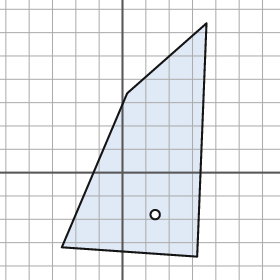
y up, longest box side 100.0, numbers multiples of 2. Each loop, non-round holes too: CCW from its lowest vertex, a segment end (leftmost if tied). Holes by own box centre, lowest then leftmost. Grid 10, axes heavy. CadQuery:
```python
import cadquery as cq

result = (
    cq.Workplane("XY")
    .moveTo(32.0, -36.0)
    .lineTo(36.0, 64.0)
    .lineTo(2.0, 34.0)
    .lineTo(-26.0, -32.0)
    .close()
    .moveTo(14.0, -18.0)
    .circle(2.0)
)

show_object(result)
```